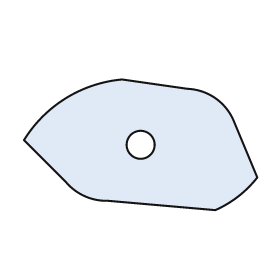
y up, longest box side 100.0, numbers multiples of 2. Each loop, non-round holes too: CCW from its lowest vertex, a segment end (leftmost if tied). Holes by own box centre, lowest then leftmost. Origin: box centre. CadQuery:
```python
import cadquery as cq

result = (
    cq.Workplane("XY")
    .moveTo(32.0, -28.0)
    .threePointArc((42.0, -22.0), (50.0, -14.0))
    .lineTo(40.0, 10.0)
    .threePointArc((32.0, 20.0), (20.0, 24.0))
    .lineTo(-8.0, 28.0)
    .threePointArc((-32.0, 20.0), (-50.0, 2.0))
    .lineTo(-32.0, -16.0)
    .threePointArc((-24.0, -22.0), (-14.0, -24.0))
    .close()
    .moveTo(0.0, 0.0)
    .circle(6.0)
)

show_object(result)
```